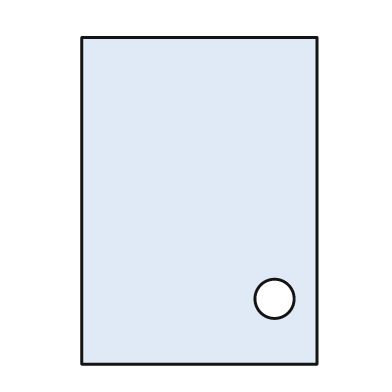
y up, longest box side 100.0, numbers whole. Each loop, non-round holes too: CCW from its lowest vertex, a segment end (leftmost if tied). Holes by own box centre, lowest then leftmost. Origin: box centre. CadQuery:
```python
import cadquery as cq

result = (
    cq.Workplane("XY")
    .moveTo(-36.0, -50.0)
    .lineTo(36.0, -50.0)
    .lineTo(36.0, 50.0)
    .lineTo(-36.0, 50.0)
    .close()
    .moveTo(23.0, -30.0)
    .circle(6.0)
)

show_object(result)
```